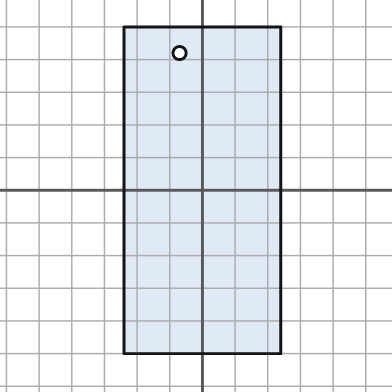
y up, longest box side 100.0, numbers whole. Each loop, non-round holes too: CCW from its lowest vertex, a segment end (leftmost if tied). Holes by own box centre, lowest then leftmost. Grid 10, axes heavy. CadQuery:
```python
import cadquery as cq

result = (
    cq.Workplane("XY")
    .moveTo(-24.0, -50.0)
    .lineTo(24.0, -50.0)
    .lineTo(24.0, 50.0)
    .lineTo(-24.0, 50.0)
    .close()
    .moveTo(-7.0, 42.0)
    .circle(2.0)
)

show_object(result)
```